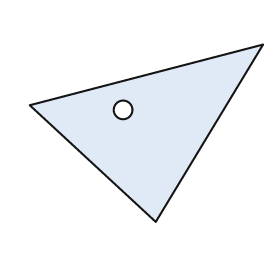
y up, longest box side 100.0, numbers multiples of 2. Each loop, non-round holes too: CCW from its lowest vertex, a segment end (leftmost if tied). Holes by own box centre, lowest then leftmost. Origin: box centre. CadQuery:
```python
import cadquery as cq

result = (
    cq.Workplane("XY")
    .moveTo(4.0, -38.0)
    .lineTo(50.0, 38.0)
    .lineTo(-50.0, 12.0)
    .close()
    .moveTo(-10.0, 10.0)
    .circle(4.0)
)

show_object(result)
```